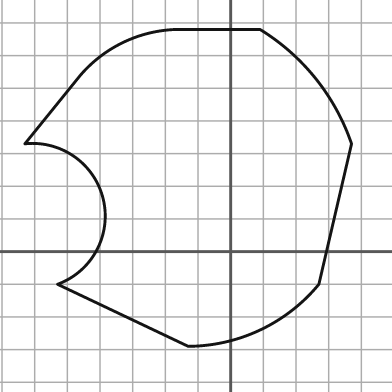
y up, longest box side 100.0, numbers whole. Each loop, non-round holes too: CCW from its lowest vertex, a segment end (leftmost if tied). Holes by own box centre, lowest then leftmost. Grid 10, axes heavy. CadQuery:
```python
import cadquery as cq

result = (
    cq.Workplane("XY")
    .moveTo(-13.0, -29.0)
    .threePointArc((9.0, -24.0), (27.0, -10.0))
    .lineTo(37.0, 33.0)
    .threePointArc((26.0, 53.0), (9.0, 68.0))
    .lineTo(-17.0, 68.0)
    .threePointArc((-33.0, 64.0), (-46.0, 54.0))
    .lineTo(-63.0, 33.0)
    .threePointArc((-39.0, 16.0), (-53.0, -10.0))
    .close()
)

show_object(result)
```